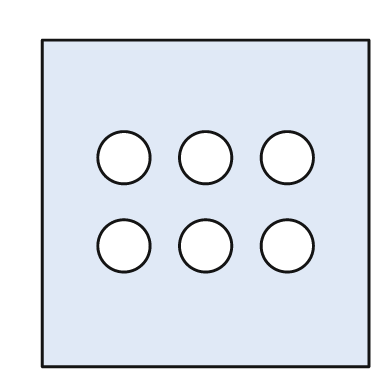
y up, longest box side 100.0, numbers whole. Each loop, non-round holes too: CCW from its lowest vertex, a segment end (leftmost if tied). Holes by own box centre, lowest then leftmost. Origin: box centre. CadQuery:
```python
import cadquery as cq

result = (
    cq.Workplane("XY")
    .moveTo(-50.0, -50.0)
    .lineTo(50.0, -50.0)
    .lineTo(50.0, 50.0)
    .lineTo(-50.0, 50.0)
    .close()
    .moveTo(-25.0, -13.0)
    .circle(8.0)
    .moveTo(0.0, -13.0)
    .circle(8.0)
    .moveTo(25.0, -13.0)
    .circle(8.0)
    .moveTo(-25.0, 14.0)
    .circle(8.0)
    .moveTo(0.0, 14.0)
    .circle(8.0)
    .moveTo(25.0, 14.0)
    .circle(8.0)
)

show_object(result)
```